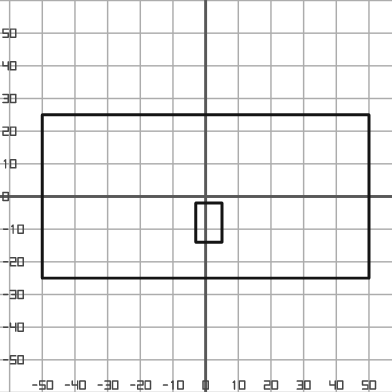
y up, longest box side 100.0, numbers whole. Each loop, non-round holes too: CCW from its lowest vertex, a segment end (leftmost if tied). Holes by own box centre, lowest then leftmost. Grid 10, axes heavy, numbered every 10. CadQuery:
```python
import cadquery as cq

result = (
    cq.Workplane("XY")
    .moveTo(-50.0, -25.0)
    .lineTo(50.0, -25.0)
    .lineTo(50.0, 25.0)
    .lineTo(-50.0, 25.0)
    .close()
    .moveTo(-3.0, -14.0)
    .lineTo(5.0, -14.0)
    .lineTo(5.0, -2.0)
    .lineTo(-3.0, -2.0)
    .close()
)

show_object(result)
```